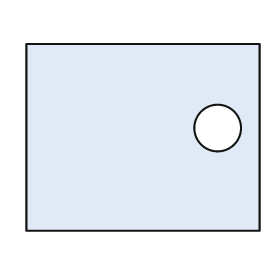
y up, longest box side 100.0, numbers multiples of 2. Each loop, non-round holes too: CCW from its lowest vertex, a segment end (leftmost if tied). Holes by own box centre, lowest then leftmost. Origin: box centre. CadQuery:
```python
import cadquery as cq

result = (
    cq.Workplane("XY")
    .moveTo(-50.0, -40.0)
    .lineTo(50.0, -40.0)
    .lineTo(50.0, 40.0)
    .lineTo(-50.0, 40.0)
    .close()
    .moveTo(32.0, 4.0)
    .circle(10.0)
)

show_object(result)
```